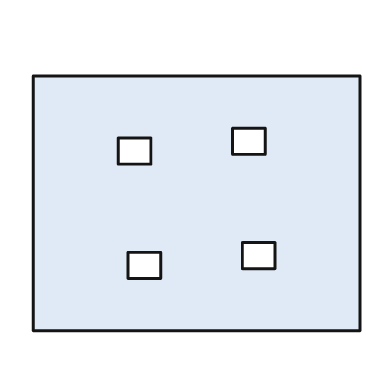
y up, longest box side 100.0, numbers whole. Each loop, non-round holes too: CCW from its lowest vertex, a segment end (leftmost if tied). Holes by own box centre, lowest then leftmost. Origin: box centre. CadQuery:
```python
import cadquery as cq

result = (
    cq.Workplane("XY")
    .moveTo(-50.0, -39.0)
    .lineTo(50.0, -39.0)
    .lineTo(50.0, 39.0)
    .lineTo(-50.0, 39.0)
    .close()
    .moveTo(-21.0, -23.0)
    .lineTo(-11.0, -23.0)
    .lineTo(-11.0, -15.0)
    .lineTo(-21.0, -15.0)
    .close()
    .moveTo(14.0, -20.0)
    .lineTo(24.0, -20.0)
    .lineTo(24.0, -12.0)
    .lineTo(14.0, -12.0)
    .close()
    .moveTo(-24.0, 12.0)
    .lineTo(-14.0, 12.0)
    .lineTo(-14.0, 20.0)
    .lineTo(-24.0, 20.0)
    .close()
    .moveTo(11.0, 15.0)
    .lineTo(21.0, 15.0)
    .lineTo(21.0, 23.0)
    .lineTo(11.0, 23.0)
    .close()
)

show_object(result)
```